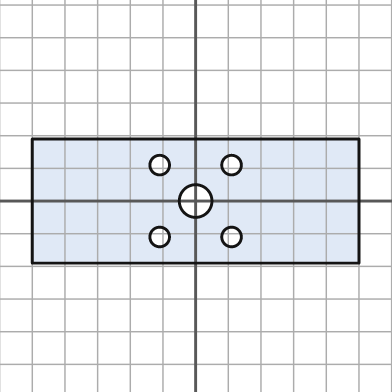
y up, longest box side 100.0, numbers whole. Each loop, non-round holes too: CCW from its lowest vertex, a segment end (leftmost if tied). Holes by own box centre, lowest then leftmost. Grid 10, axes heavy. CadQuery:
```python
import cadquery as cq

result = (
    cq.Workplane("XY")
    .moveTo(-50.0, -19.0)
    .lineTo(50.0, -19.0)
    .lineTo(50.0, 19.0)
    .lineTo(-50.0, 19.0)
    .close()
    .moveTo(-11.0, -11.0)
    .circle(3.0)
    .moveTo(11.0, -11.0)
    .circle(3.0)
    .moveTo(0.0, 0.0)
    .circle(5.0)
    .moveTo(-11.0, 11.0)
    .circle(3.0)
    .moveTo(11.0, 11.0)
    .circle(3.0)
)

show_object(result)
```